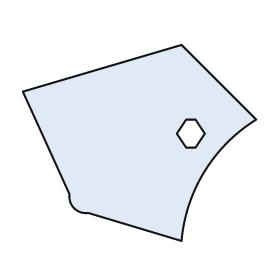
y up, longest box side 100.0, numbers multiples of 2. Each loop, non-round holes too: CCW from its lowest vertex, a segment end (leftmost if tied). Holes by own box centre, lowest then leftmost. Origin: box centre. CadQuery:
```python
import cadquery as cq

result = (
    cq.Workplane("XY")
    .moveTo(18.0, -42.0)
    .threePointArc((28.0, -12.0), (50.0, 10.0))
    .lineTo(18.0, 42.0)
    .lineTo(-50.0, 22.0)
    .lineTo(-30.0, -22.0)
    .threePointArc((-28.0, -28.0), (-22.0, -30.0))
    .close()
    .moveTo(20.0, -2.0)
    .lineTo(24.0, -2.0)
    .lineTo(28.0, 4.0)
    .lineTo(24.0, 10.0)
    .lineTo(20.0, 10.0)
    .lineTo(16.0, 4.0)
    .close()
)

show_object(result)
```